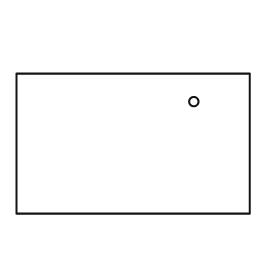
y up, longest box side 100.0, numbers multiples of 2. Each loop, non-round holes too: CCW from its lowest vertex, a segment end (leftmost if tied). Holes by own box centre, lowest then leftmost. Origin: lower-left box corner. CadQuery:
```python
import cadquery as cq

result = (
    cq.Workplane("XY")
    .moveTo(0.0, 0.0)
    .lineTo(100.0, 0.0)
    .lineTo(100.0, 60.0)
    .lineTo(0.0, 60.0)
    .close()
    .moveTo(76.0, 48.0)
    .circle(2.0)
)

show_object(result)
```